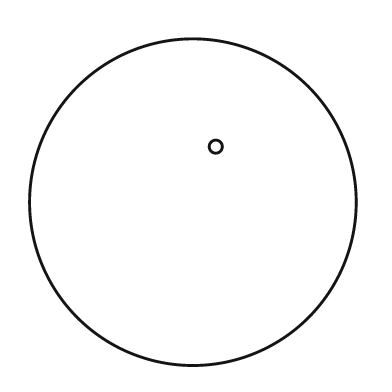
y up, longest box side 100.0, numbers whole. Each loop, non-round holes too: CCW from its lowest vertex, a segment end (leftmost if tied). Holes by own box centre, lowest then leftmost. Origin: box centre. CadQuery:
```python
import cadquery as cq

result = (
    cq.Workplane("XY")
    .moveTo(0.0, 0.0)
    .circle(50.0)
    .moveTo(7.0, 17.0)
    .circle(2.0)
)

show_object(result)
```